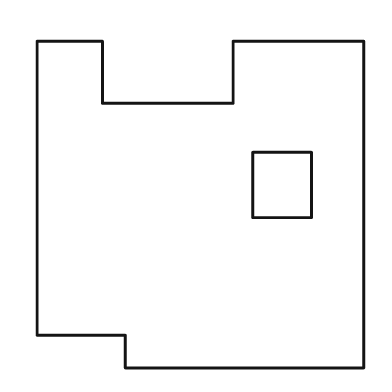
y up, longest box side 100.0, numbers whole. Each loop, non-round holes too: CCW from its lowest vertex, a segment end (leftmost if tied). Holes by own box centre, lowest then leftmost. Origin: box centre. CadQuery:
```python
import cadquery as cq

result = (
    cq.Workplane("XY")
    .moveTo(-23.0, -50.0)
    .lineTo(50.0, -50.0)
    .lineTo(50.0, 50.0)
    .lineTo(10.0, 50.0)
    .lineTo(10.0, 31.0)
    .lineTo(-30.0, 31.0)
    .lineTo(-30.0, 50.0)
    .lineTo(-50.0, 50.0)
    .lineTo(-50.0, -40.0)
    .lineTo(-23.0, -40.0)
    .close()
    .moveTo(16.0, -4.0)
    .lineTo(34.0, -4.0)
    .lineTo(34.0, 16.0)
    .lineTo(16.0, 16.0)
    .close()
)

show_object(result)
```